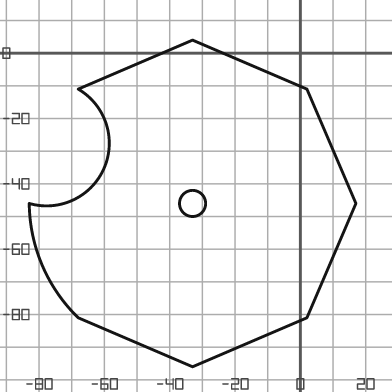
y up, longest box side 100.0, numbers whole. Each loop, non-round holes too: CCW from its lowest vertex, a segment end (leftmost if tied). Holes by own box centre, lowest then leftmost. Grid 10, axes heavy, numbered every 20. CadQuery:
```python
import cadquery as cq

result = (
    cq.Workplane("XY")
    .moveTo(-33.0, -96.0)
    .lineTo(2.0, -81.0)
    .lineTo(17.0, -46.0)
    .lineTo(2.0, -11.0)
    .lineTo(-33.0, 4.0)
    .lineTo(-68.0, -11.0)
    .threePointArc((-60.0, -35.0), (-83.0, -46.0))
    .threePointArc((-79.0, -65.0), (-68.0, -81.0))
    .close()
    .moveTo(-33.0, -46.0)
    .circle(4.0)
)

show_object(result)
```